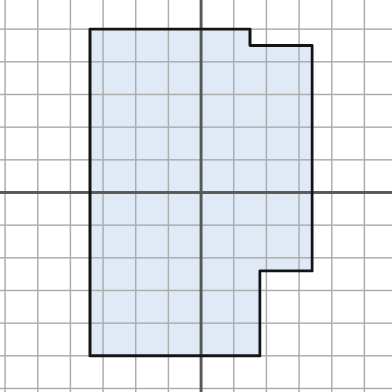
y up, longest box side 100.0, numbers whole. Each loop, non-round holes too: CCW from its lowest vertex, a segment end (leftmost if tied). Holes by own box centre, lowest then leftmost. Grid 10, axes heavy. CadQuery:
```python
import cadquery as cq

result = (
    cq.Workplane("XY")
    .moveTo(-34.0, -50.0)
    .lineTo(18.0, -50.0)
    .lineTo(18.0, -24.0)
    .lineTo(34.0, -24.0)
    .lineTo(34.0, 45.0)
    .lineTo(15.0, 45.0)
    .lineTo(15.0, 50.0)
    .lineTo(-34.0, 50.0)
    .close()
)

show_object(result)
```